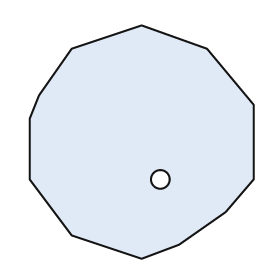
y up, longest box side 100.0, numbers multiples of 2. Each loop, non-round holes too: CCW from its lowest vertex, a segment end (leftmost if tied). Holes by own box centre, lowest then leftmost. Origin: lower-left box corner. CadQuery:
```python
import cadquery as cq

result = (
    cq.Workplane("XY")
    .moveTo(48.0, 0.0)
    .lineTo(64.0, 6.0)
    .lineTo(84.0, 20.0)
    .lineTo(96.0, 34.0)
    .lineTo(96.0, 66.0)
    .lineTo(76.0, 90.0)
    .lineTo(48.0, 100.0)
    .lineTo(18.0, 90.0)
    .lineTo(4.0, 70.0)
    .lineTo(0.0, 60.0)
    .lineTo(0.0, 34.0)
    .lineTo(18.0, 10.0)
    .close()
    .moveTo(56.0, 34.0)
    .circle(4.0)
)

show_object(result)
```